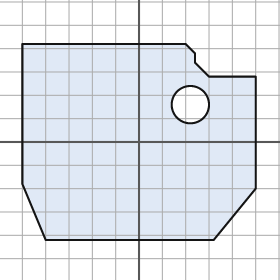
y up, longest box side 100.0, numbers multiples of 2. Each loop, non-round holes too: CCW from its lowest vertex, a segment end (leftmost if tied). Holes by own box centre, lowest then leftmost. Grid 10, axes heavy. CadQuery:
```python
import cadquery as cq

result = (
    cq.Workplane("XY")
    .moveTo(-40.0, -42.0)
    .lineTo(32.0, -42.0)
    .lineTo(50.0, -20.0)
    .lineTo(50.0, 28.0)
    .lineTo(30.0, 28.0)
    .lineTo(24.0, 34.0)
    .lineTo(24.0, 38.0)
    .lineTo(20.0, 42.0)
    .lineTo(-50.0, 42.0)
    .lineTo(-50.0, -18.0)
    .close()
    .moveTo(22.0, 16.0)
    .circle(8.0)
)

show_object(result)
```